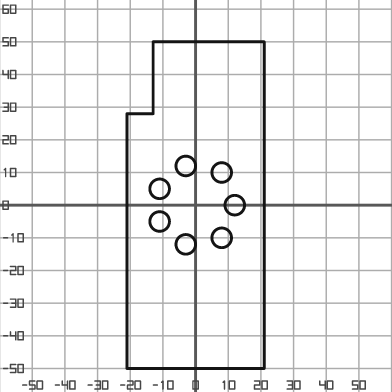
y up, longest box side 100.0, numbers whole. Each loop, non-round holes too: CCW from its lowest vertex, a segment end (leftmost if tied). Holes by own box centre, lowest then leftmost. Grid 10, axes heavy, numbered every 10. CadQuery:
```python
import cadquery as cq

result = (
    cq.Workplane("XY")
    .moveTo(-21.0, -50.0)
    .lineTo(21.0, -50.0)
    .lineTo(21.0, 50.0)
    .lineTo(-13.0, 50.0)
    .lineTo(-13.0, 28.0)
    .lineTo(-21.0, 28.0)
    .close()
    .moveTo(-3.0, -12.0)
    .circle(3.0)
    .moveTo(8.0, -10.0)
    .circle(3.0)
    .moveTo(-11.0, -5.0)
    .circle(3.0)
    .moveTo(12.0, 0.0)
    .circle(3.0)
    .moveTo(-11.0, 5.0)
    .circle(3.0)
    .moveTo(8.0, 10.0)
    .circle(3.0)
    .moveTo(-3.0, 12.0)
    .circle(3.0)
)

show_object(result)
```